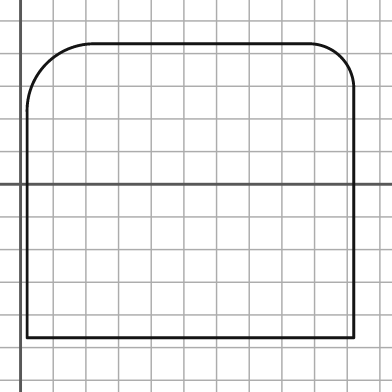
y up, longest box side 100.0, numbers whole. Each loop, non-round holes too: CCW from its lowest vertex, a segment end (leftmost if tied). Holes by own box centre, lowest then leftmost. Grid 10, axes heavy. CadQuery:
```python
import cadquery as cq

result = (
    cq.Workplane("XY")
    .moveTo(2.0, -47.0)
    .lineTo(102.0, -47.0)
    .lineTo(102.0, 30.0)
    .threePointArc((98.0, 39.0), (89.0, 43.0))
    .lineTo(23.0, 43.0)
    .threePointArc((8.0, 37.0), (2.0, 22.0))
    .close()
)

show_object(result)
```